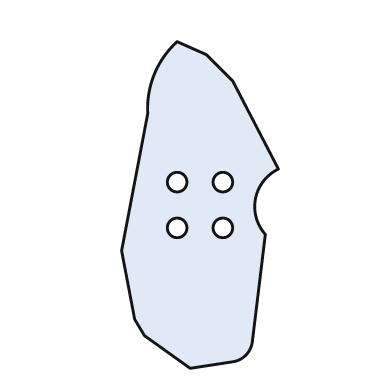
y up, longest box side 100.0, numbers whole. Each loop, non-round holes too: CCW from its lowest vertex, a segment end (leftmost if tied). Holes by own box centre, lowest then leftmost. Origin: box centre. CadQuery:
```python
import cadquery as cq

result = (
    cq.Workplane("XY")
    .moveTo(-3.0, -50.0)
    .lineTo(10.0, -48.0)
    .threePointArc((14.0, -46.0), (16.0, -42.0))
    .lineTo(20.0, -9.0)
    .threePointArc((17.0, 2.0), (24.0, 11.0))
    .lineTo(10.0, 38.0)
    .lineTo(2.0, 46.0)
    .lineTo(-7.0, 50.0)
    .threePointArc((-14.0, 40.0), (-16.0, 28.0))
    .lineTo(-24.0, -14.0)
    .lineTo(-20.0, -35.0)
    .lineTo(-17.0, -40.0)
    .close()
    .moveTo(-7.0, -7.0)
    .circle(3.0)
    .moveTo(7.0, -7.0)
    .circle(3.0)
    .moveTo(-7.0, 7.0)
    .circle(3.0)
    .moveTo(7.0, 7.0)
    .circle(3.0)
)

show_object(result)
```